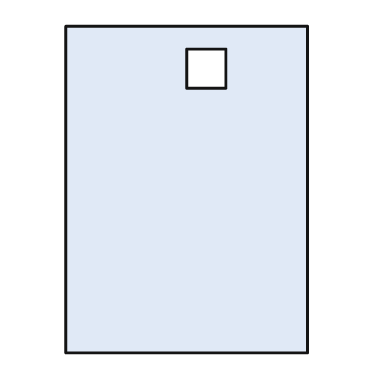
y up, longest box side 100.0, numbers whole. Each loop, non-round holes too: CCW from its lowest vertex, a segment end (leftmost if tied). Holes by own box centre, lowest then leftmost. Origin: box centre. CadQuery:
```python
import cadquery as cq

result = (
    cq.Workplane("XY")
    .moveTo(-37.0, -50.0)
    .lineTo(37.0, -50.0)
    .lineTo(37.0, 50.0)
    .lineTo(-37.0, 50.0)
    .close()
    .moveTo(0.0, 31.0)
    .lineTo(12.0, 31.0)
    .lineTo(12.0, 43.0)
    .lineTo(0.0, 43.0)
    .close()
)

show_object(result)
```